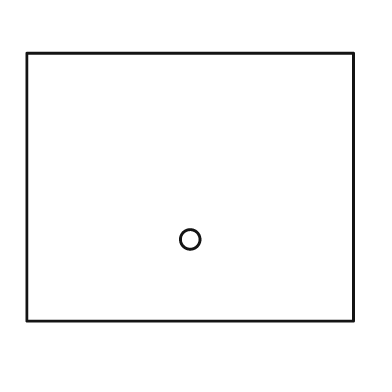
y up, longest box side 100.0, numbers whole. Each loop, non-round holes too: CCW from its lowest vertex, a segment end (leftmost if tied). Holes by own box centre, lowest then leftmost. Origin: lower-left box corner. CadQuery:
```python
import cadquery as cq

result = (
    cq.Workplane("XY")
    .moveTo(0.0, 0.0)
    .lineTo(100.0, 0.0)
    .lineTo(100.0, 82.0)
    .lineTo(0.0, 82.0)
    .close()
    .moveTo(50.0, 25.0)
    .circle(3.0)
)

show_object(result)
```